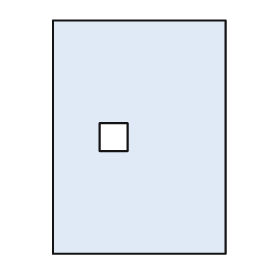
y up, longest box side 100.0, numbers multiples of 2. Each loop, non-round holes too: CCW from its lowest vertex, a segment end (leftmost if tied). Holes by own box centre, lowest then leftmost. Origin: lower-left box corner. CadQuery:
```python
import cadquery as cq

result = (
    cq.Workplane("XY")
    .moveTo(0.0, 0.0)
    .lineTo(74.0, 0.0)
    .lineTo(74.0, 100.0)
    .lineTo(0.0, 100.0)
    .close()
    .moveTo(20.0, 44.0)
    .lineTo(32.0, 44.0)
    .lineTo(32.0, 56.0)
    .lineTo(20.0, 56.0)
    .close()
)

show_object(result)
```